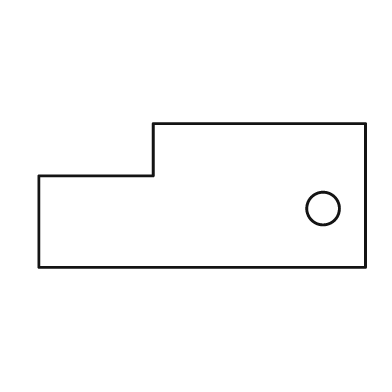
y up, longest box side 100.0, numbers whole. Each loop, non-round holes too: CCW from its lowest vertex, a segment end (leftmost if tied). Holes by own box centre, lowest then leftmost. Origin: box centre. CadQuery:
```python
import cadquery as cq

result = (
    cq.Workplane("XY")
    .moveTo(-50.0, -22.0)
    .lineTo(50.0, -22.0)
    .lineTo(50.0, 22.0)
    .lineTo(-15.0, 22.0)
    .lineTo(-15.0, 6.0)
    .lineTo(-50.0, 6.0)
    .close()
    .moveTo(37.0, -4.0)
    .circle(5.0)
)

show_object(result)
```